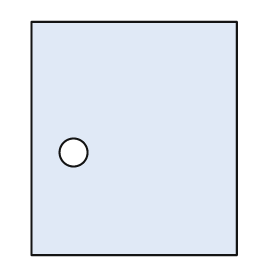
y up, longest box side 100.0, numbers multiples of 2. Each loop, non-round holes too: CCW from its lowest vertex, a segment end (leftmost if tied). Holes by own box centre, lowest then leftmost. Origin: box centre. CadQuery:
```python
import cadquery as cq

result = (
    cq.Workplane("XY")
    .moveTo(-44.0, -50.0)
    .lineTo(44.0, -50.0)
    .lineTo(44.0, 50.0)
    .lineTo(-44.0, 50.0)
    .close()
    .moveTo(-26.0, -6.0)
    .circle(6.0)
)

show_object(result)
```